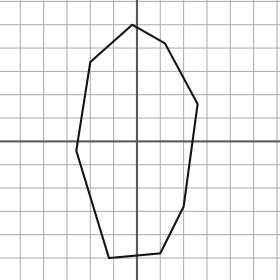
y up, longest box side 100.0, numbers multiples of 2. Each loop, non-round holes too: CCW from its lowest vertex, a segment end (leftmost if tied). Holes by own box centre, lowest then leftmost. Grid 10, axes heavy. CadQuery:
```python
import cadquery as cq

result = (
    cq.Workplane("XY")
    .moveTo(-12.0, -50.0)
    .lineTo(10.0, -48.0)
    .lineTo(20.0, -28.0)
    .lineTo(26.0, 16.0)
    .lineTo(12.0, 42.0)
    .lineTo(-2.0, 50.0)
    .lineTo(-20.0, 34.0)
    .lineTo(-26.0, -4.0)
    .close()
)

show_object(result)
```